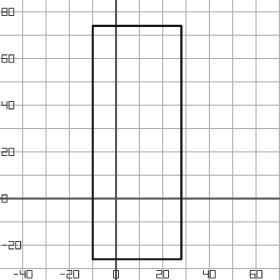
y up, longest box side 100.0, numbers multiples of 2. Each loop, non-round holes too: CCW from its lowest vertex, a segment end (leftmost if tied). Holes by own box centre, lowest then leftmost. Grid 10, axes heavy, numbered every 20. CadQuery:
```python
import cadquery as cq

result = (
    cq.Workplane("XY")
    .moveTo(-10.0, -26.0)
    .lineTo(28.0, -26.0)
    .lineTo(28.0, 74.0)
    .lineTo(-10.0, 74.0)
    .close()
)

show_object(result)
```